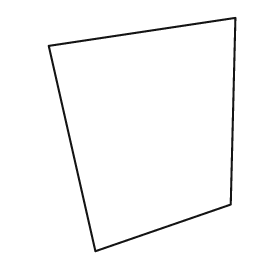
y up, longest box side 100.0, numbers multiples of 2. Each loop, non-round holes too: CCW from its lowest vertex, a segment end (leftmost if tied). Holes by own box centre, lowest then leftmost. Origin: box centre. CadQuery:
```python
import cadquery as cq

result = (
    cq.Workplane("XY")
    .moveTo(-20.0, -50.0)
    .lineTo(38.0, -30.0)
    .lineTo(40.0, 50.0)
    .lineTo(-40.0, 38.0)
    .close()
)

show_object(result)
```